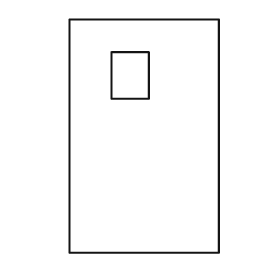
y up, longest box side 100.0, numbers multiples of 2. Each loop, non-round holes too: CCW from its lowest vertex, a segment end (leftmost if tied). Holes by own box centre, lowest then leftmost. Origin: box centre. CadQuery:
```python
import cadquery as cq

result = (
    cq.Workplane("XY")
    .moveTo(-32.0, -50.0)
    .lineTo(32.0, -50.0)
    .lineTo(32.0, 50.0)
    .lineTo(-32.0, 50.0)
    .close()
    .moveTo(-14.0, 16.0)
    .lineTo(2.0, 16.0)
    .lineTo(2.0, 36.0)
    .lineTo(-14.0, 36.0)
    .close()
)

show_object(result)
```